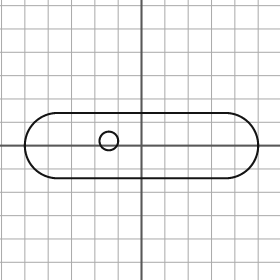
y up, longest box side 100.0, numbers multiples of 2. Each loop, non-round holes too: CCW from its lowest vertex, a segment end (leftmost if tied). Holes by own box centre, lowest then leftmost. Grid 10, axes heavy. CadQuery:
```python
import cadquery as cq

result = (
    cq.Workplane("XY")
    .moveTo(-36.0, -14.0)
    .lineTo(36.0, -14.0)
    .threePointArc((50.0, 0.0), (36.0, 14.0))
    .lineTo(-36.0, 14.0)
    .threePointArc((-50.0, 0.0), (-36.0, -14.0))
    .close()
    .moveTo(-14.0, 2.0)
    .circle(4.0)
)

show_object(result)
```